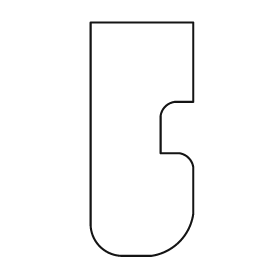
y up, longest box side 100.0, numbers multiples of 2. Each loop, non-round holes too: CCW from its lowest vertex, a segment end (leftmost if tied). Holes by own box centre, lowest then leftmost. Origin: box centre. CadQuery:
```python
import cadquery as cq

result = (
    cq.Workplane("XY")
    .moveTo(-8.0, -50.0)
    .lineTo(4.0, -50.0)
    .threePointArc((16.0, -44.0), (22.0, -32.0))
    .lineTo(22.0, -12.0)
    .threePointArc((20.0, -8.0), (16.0, -6.0))
    .lineTo(8.0, -6.0)
    .lineTo(8.0, 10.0)
    .threePointArc((10.0, 14.0), (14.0, 16.0))
    .lineTo(22.0, 16.0)
    .lineTo(22.0, 50.0)
    .lineTo(-22.0, 50.0)
    .lineTo(-22.0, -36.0)
    .threePointArc((-18.0, -46.0), (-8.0, -50.0))
    .close()
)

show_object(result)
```